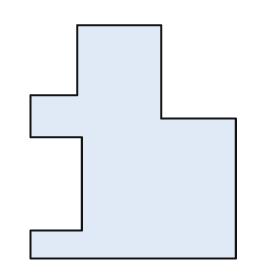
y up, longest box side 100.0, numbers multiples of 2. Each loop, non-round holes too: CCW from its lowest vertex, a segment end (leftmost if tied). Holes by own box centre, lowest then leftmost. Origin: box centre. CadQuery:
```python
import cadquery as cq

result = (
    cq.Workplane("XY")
    .moveTo(-44.0, -50.0)
    .lineTo(44.0, -50.0)
    .lineTo(44.0, 10.0)
    .lineTo(12.0, 10.0)
    .lineTo(12.0, 50.0)
    .lineTo(-24.0, 50.0)
    .lineTo(-24.0, 20.0)
    .lineTo(-44.0, 20.0)
    .lineTo(-44.0, 2.0)
    .lineTo(-22.0, 2.0)
    .lineTo(-22.0, -38.0)
    .lineTo(-44.0, -38.0)
    .close()
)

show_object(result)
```